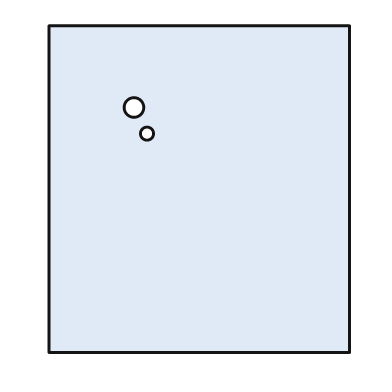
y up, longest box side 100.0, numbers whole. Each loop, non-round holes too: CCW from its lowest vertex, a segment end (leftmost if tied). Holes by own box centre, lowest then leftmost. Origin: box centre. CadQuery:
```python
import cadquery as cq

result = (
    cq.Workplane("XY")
    .moveTo(-46.0, -50.0)
    .lineTo(46.0, -50.0)
    .lineTo(46.0, 50.0)
    .lineTo(-46.0, 50.0)
    .close()
    .moveTo(-16.0, 17.0)
    .circle(2.0)
    .moveTo(-20.0, 25.0)
    .circle(3.0)
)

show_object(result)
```